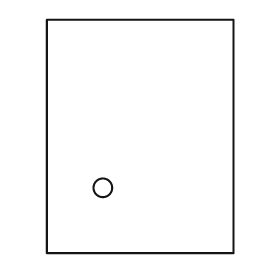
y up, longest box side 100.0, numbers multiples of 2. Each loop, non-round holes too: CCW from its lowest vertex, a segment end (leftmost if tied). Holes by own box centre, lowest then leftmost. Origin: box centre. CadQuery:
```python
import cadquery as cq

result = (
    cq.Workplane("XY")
    .moveTo(-40.0, -50.0)
    .lineTo(40.0, -50.0)
    .lineTo(40.0, 50.0)
    .lineTo(-40.0, 50.0)
    .close()
    .moveTo(-16.0, -22.0)
    .circle(4.0)
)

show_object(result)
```